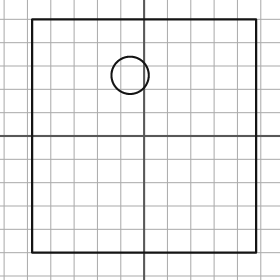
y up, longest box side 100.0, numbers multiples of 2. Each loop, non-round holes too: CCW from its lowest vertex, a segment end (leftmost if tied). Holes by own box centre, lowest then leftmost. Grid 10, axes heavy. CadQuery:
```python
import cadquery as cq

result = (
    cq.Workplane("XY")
    .moveTo(-48.0, -50.0)
    .lineTo(48.0, -50.0)
    .lineTo(48.0, 50.0)
    .lineTo(-48.0, 50.0)
    .close()
    .moveTo(-6.0, 26.0)
    .circle(8.0)
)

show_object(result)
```